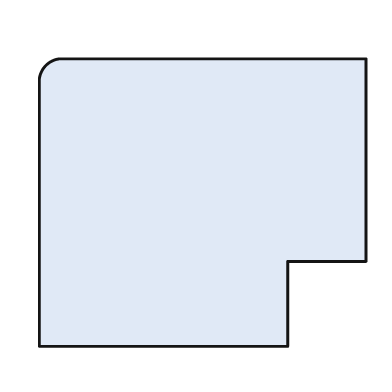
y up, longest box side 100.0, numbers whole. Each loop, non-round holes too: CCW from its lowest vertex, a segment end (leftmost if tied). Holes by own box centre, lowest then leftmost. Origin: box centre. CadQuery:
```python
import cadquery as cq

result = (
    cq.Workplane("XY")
    .moveTo(-50.0, -44.0)
    .lineTo(26.0, -44.0)
    .lineTo(26.0, -18.0)
    .lineTo(50.0, -18.0)
    .lineTo(50.0, 44.0)
    .lineTo(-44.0, 44.0)
    .threePointArc((-48.0, 42.0), (-50.0, 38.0))
    .close()
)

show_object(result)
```